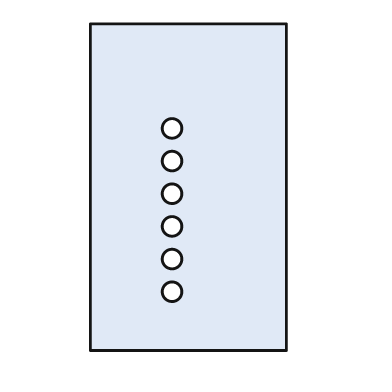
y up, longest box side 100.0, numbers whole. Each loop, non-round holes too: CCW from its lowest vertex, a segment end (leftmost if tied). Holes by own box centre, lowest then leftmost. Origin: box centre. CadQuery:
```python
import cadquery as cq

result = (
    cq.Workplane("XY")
    .moveTo(-30.0, -50.0)
    .lineTo(30.0, -50.0)
    .lineTo(30.0, 50.0)
    .lineTo(-30.0, 50.0)
    .close()
    .moveTo(-5.0, -32.0)
    .circle(3.0)
    .moveTo(-5.0, -22.0)
    .circle(3.0)
    .moveTo(-5.0, -12.0)
    .circle(3.0)
    .moveTo(-5.0, -2.0)
    .circle(3.0)
    .moveTo(-5.0, 8.0)
    .circle(3.0)
    .moveTo(-5.0, 18.0)
    .circle(3.0)
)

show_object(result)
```